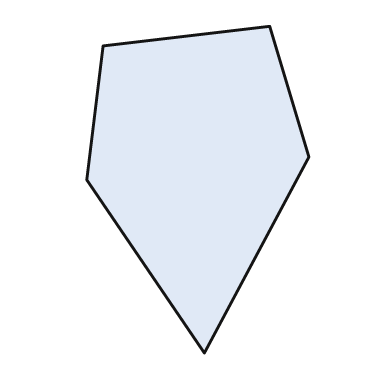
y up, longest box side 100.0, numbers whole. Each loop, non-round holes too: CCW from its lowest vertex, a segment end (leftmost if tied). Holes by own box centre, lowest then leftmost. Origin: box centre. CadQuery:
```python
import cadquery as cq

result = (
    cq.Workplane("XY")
    .moveTo(2.0, -50.0)
    .lineTo(34.0, 10.0)
    .lineTo(22.0, 50.0)
    .lineTo(-29.0, 44.0)
    .lineTo(-34.0, 3.0)
    .close()
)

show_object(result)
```